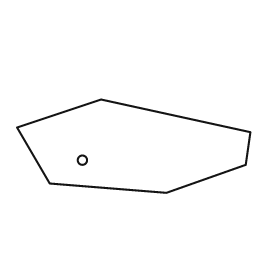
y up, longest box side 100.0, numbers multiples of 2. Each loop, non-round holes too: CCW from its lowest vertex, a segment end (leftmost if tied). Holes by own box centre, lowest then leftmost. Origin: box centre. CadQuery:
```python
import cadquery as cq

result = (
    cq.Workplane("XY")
    .moveTo(14.0, -20.0)
    .lineTo(48.0, -8.0)
    .lineTo(50.0, 6.0)
    .lineTo(-14.0, 20.0)
    .lineTo(-50.0, 8.0)
    .lineTo(-36.0, -16.0)
    .close()
    .moveTo(-22.0, -6.0)
    .circle(2.0)
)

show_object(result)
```